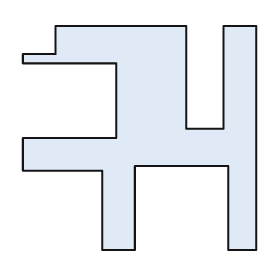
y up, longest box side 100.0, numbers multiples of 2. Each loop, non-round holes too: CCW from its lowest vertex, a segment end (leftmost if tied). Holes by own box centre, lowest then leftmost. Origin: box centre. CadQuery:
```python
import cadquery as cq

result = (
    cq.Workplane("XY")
    .moveTo(-16.0, -48.0)
    .lineTo(-2.0, -48.0)
    .lineTo(-2.0, -12.0)
    .lineTo(38.0, -12.0)
    .lineTo(38.0, -48.0)
    .lineTo(50.0, -48.0)
    .lineTo(50.0, 48.0)
    .lineTo(36.0, 48.0)
    .lineTo(36.0, 4.0)
    .lineTo(20.0, 4.0)
    .lineTo(20.0, 48.0)
    .lineTo(-36.0, 48.0)
    .lineTo(-36.0, 36.0)
    .lineTo(-50.0, 36.0)
    .lineTo(-50.0, 32.0)
    .lineTo(-10.0, 32.0)
    .lineTo(-10.0, 0.0)
    .lineTo(-50.0, 0.0)
    .lineTo(-50.0, -14.0)
    .lineTo(-16.0, -14.0)
    .close()
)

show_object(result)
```